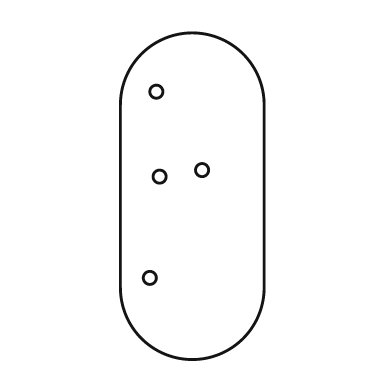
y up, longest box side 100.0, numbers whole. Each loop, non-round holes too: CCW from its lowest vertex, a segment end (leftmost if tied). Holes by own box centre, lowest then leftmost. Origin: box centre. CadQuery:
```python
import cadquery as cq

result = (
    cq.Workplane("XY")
    .moveTo(-22.0, -28.0)
    .threePointArc((0.0, -50.0), (22.0, -28.0))
    .lineTo(22.0, 28.0)
    .threePointArc((0.0, 50.0), (-22.0, 28.0))
    .close()
    .moveTo(-13.0, -25.0)
    .circle(2.0)
    .moveTo(-10.0, 6.0)
    .circle(2.0)
    .moveTo(3.0, 8.0)
    .circle(2.0)
    .moveTo(-11.0, 32.0)
    .circle(2.0)
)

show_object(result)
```